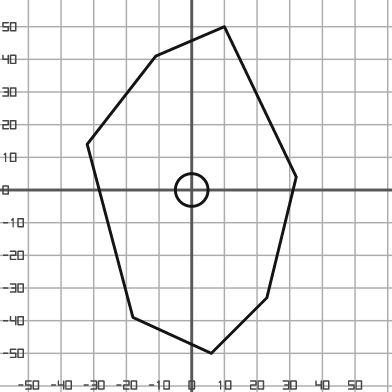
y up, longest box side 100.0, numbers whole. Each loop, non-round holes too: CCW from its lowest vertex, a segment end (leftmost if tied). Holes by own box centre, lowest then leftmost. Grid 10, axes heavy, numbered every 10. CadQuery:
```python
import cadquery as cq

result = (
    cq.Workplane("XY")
    .moveTo(6.0, -50.0)
    .lineTo(23.0, -33.0)
    .lineTo(32.0, 4.0)
    .lineTo(10.0, 50.0)
    .lineTo(-11.0, 41.0)
    .lineTo(-32.0, 14.0)
    .lineTo(-18.0, -39.0)
    .close()
    .moveTo(0.0, 0.0)
    .circle(5.0)
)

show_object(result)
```